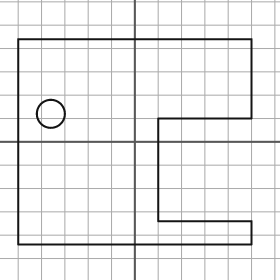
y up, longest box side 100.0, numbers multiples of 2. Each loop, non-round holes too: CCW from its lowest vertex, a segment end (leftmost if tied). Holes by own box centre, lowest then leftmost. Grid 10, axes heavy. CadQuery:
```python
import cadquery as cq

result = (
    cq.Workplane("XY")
    .moveTo(-50.0, -44.0)
    .lineTo(50.0, -44.0)
    .lineTo(50.0, -34.0)
    .lineTo(10.0, -34.0)
    .lineTo(10.0, 10.0)
    .lineTo(50.0, 10.0)
    .lineTo(50.0, 44.0)
    .lineTo(-50.0, 44.0)
    .close()
    .moveTo(-36.0, 12.0)
    .circle(6.0)
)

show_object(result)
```